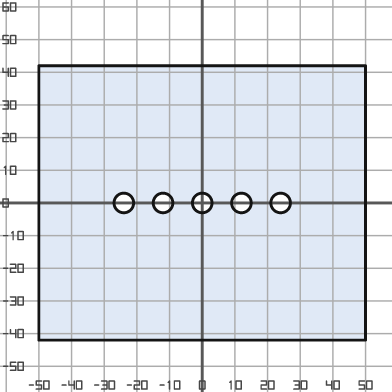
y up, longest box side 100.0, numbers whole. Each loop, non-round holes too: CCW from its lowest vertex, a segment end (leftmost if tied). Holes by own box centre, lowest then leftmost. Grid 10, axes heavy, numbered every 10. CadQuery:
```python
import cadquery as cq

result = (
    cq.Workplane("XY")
    .moveTo(-50.0, -42.0)
    .lineTo(50.0, -42.0)
    .lineTo(50.0, 42.0)
    .lineTo(-50.0, 42.0)
    .close()
    .moveTo(-24.0, 0.0)
    .circle(3.0)
    .moveTo(-12.0, 0.0)
    .circle(3.0)
    .moveTo(0.0, 0.0)
    .circle(3.0)
    .moveTo(12.0, 0.0)
    .circle(3.0)
    .moveTo(24.0, 0.0)
    .circle(3.0)
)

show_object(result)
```